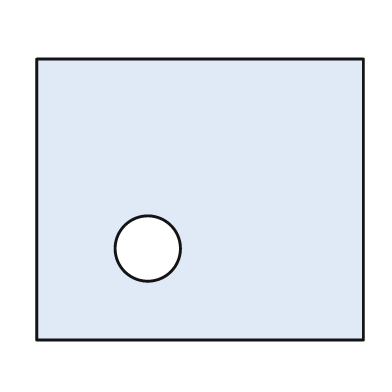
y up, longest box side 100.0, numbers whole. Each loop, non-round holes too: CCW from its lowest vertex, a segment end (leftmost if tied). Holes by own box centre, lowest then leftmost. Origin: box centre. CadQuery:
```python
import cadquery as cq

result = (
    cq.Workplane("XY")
    .moveTo(-50.0, -43.0)
    .lineTo(50.0, -43.0)
    .lineTo(50.0, 43.0)
    .lineTo(-50.0, 43.0)
    .close()
    .moveTo(-16.0, -15.0)
    .circle(10.0)
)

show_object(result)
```